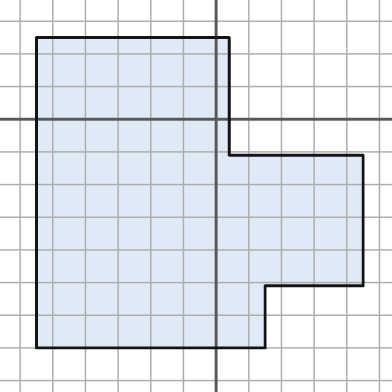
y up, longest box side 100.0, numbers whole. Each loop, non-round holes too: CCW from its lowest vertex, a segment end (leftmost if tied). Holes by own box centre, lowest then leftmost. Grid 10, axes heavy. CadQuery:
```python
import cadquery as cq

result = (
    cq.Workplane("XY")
    .moveTo(-55.0, -70.0)
    .lineTo(15.0, -70.0)
    .lineTo(15.0, -51.0)
    .lineTo(45.0, -51.0)
    .lineTo(45.0, -11.0)
    .lineTo(4.0, -11.0)
    .lineTo(4.0, 25.0)
    .lineTo(-55.0, 25.0)
    .close()
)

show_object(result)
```